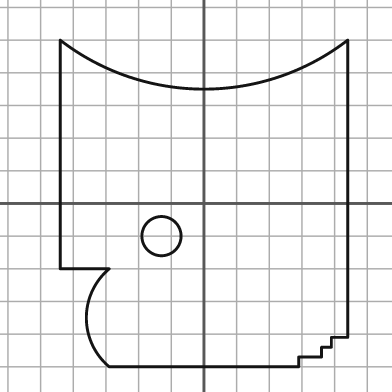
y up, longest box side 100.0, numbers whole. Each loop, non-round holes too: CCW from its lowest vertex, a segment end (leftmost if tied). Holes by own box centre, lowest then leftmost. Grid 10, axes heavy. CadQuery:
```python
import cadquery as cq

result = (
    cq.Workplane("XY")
    .moveTo(-29.0, -50.0)
    .lineTo(29.0, -50.0)
    .lineTo(29.0, -47.0)
    .lineTo(36.0, -47.0)
    .lineTo(36.0, -44.0)
    .lineTo(39.0, -44.0)
    .lineTo(39.0, -41.0)
    .lineTo(44.0, -41.0)
    .lineTo(44.0, 50.0)
    .threePointArc((0.0, 35.0), (-44.0, 50.0))
    .lineTo(-44.0, -20.0)
    .lineTo(-29.0, -20.0)
    .threePointArc((-36.0, -35.0), (-29.0, -50.0))
    .close()
    .moveTo(-13.0, -10.0)
    .circle(6.0)
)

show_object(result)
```